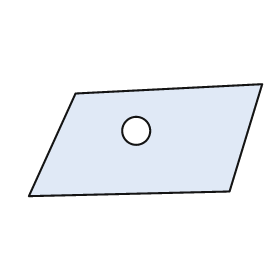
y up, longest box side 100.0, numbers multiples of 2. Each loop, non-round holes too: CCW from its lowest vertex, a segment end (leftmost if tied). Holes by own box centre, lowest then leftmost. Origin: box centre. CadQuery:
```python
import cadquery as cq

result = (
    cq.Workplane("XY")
    .moveTo(-50.0, -24.0)
    .lineTo(36.0, -22.0)
    .lineTo(50.0, 24.0)
    .lineTo(-30.0, 20.0)
    .close()
    .moveTo(-4.0, 4.0)
    .circle(6.0)
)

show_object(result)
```